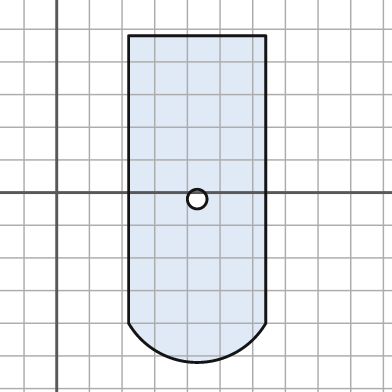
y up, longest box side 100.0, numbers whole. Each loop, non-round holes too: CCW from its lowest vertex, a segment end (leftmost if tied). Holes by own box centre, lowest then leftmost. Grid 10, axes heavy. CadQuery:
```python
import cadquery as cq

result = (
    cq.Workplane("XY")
    .moveTo(22.0, -40.0)
    .threePointArc((43.0, -52.0), (64.0, -40.0))
    .lineTo(64.0, 48.0)
    .lineTo(22.0, 48.0)
    .close()
    .moveTo(43.0, -2.0)
    .circle(3.0)
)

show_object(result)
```